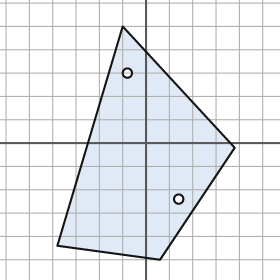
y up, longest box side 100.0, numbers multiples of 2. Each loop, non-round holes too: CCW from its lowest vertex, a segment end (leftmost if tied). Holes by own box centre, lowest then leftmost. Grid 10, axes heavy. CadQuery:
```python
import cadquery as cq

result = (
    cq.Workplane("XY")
    .moveTo(6.0, -50.0)
    .lineTo(38.0, -2.0)
    .lineTo(-10.0, 50.0)
    .lineTo(-38.0, -44.0)
    .close()
    .moveTo(14.0, -24.0)
    .circle(2.0)
    .moveTo(-8.0, 30.0)
    .circle(2.0)
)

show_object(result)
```